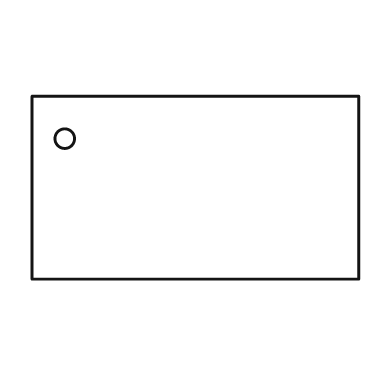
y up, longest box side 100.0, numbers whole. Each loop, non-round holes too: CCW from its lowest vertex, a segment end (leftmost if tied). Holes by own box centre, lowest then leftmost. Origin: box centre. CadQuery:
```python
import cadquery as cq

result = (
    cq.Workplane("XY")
    .moveTo(-50.0, -28.0)
    .lineTo(50.0, -28.0)
    .lineTo(50.0, 28.0)
    .lineTo(-50.0, 28.0)
    .close()
    .moveTo(-40.0, 15.0)
    .circle(3.0)
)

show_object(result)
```